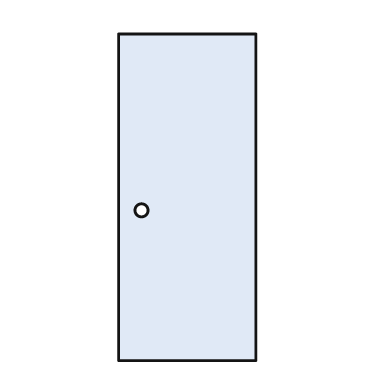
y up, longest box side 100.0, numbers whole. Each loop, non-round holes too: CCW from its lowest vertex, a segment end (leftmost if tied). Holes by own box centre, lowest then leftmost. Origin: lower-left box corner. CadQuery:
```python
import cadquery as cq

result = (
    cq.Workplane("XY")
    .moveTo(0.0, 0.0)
    .lineTo(42.0, 0.0)
    .lineTo(42.0, 100.0)
    .lineTo(0.0, 100.0)
    .close()
    .moveTo(7.0, 46.0)
    .circle(2.0)
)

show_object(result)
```